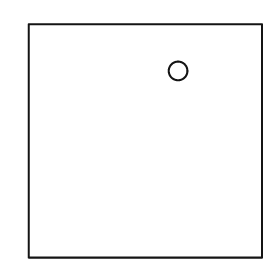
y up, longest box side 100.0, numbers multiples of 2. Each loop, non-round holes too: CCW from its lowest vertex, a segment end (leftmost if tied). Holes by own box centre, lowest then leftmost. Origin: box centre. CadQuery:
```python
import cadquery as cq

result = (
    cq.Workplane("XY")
    .moveTo(-50.0, -50.0)
    .lineTo(50.0, -50.0)
    .lineTo(50.0, 50.0)
    .lineTo(-50.0, 50.0)
    .close()
    .moveTo(14.0, 30.0)
    .circle(4.0)
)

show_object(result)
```